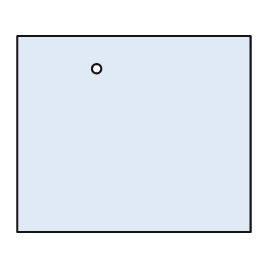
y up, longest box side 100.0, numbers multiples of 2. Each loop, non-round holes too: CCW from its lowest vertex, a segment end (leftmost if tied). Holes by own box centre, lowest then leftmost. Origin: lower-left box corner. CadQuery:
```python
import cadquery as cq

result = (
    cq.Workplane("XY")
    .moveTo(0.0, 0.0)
    .lineTo(100.0, 0.0)
    .lineTo(100.0, 84.0)
    .lineTo(0.0, 84.0)
    .close()
    .moveTo(34.0, 70.0)
    .circle(2.0)
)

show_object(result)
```